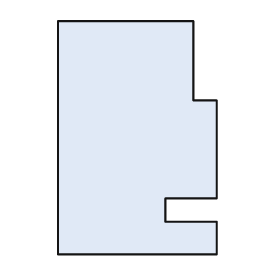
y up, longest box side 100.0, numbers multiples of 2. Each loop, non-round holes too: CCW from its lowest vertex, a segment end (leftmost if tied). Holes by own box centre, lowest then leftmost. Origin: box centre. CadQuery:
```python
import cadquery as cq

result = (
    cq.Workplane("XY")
    .moveTo(-34.0, -50.0)
    .lineTo(34.0, -50.0)
    .lineTo(34.0, -36.0)
    .lineTo(12.0, -36.0)
    .lineTo(12.0, -26.0)
    .lineTo(34.0, -26.0)
    .lineTo(34.0, 16.0)
    .lineTo(24.0, 16.0)
    .lineTo(24.0, 50.0)
    .lineTo(-34.0, 50.0)
    .close()
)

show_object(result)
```